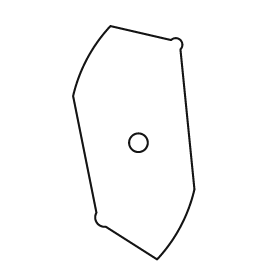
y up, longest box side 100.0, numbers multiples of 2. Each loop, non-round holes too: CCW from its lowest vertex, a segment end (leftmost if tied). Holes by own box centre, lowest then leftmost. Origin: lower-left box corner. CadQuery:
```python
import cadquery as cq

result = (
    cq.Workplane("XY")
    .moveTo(36.0, 0.0)
    .threePointArc((46.0, 14.0), (52.0, 30.0))
    .lineTo(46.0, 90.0)
    .threePointArc((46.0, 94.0), (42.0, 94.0))
    .lineTo(16.0, 100.0)
    .threePointArc((6.0, 86.0), (0.0, 70.0))
    .lineTo(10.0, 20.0)
    .threePointArc((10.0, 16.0), (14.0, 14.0))
    .close()
    .moveTo(28.0, 50.0)
    .circle(4.0)
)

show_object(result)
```